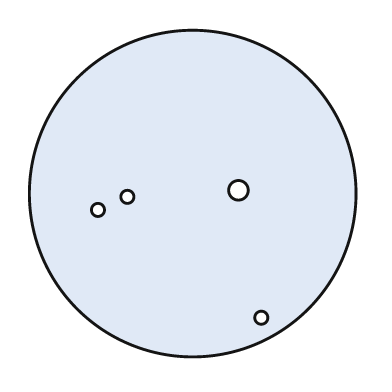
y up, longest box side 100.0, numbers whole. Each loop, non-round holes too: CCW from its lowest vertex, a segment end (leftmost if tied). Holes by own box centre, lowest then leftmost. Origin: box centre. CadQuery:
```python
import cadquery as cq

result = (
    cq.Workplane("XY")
    .moveTo(0.0, 0.0)
    .circle(50.0)
    .moveTo(21.0, -38.0)
    .circle(2.0)
    .moveTo(-29.0, -5.0)
    .circle(2.0)
    .moveTo(-20.0, -1.0)
    .circle(2.0)
    .moveTo(14.0, 1.0)
    .circle(3.0)
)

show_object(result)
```